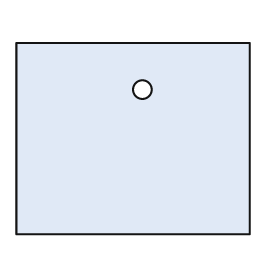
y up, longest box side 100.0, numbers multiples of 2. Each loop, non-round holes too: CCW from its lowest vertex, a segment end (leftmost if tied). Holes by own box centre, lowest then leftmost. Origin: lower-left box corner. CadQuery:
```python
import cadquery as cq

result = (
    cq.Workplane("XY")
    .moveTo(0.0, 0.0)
    .lineTo(100.0, 0.0)
    .lineTo(100.0, 82.0)
    .lineTo(0.0, 82.0)
    .close()
    .moveTo(54.0, 62.0)
    .circle(4.0)
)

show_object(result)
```